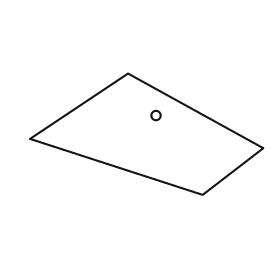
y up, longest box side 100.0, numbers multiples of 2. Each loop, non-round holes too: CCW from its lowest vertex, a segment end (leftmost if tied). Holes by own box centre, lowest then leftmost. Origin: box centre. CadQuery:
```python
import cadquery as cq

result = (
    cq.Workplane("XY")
    .moveTo(24.0, -26.0)
    .lineTo(50.0, -6.0)
    .lineTo(-8.0, 26.0)
    .lineTo(-50.0, -2.0)
    .close()
    .moveTo(4.0, 8.0)
    .circle(2.0)
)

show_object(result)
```